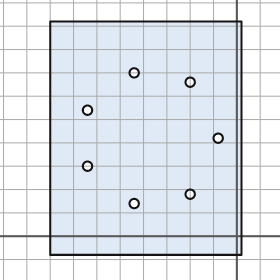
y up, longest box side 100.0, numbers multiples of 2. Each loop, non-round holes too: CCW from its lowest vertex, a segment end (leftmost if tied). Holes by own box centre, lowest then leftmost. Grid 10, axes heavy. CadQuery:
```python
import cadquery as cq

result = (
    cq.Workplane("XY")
    .moveTo(-80.0, -8.0)
    .lineTo(2.0, -8.0)
    .lineTo(2.0, 92.0)
    .lineTo(-80.0, 92.0)
    .close()
    .moveTo(-44.0, 14.0)
    .circle(2.0)
    .moveTo(-20.0, 18.0)
    .circle(2.0)
    .moveTo(-64.0, 30.0)
    .circle(2.0)
    .moveTo(-8.0, 42.0)
    .circle(2.0)
    .moveTo(-64.0, 54.0)
    .circle(2.0)
    .moveTo(-20.0, 66.0)
    .circle(2.0)
    .moveTo(-44.0, 70.0)
    .circle(2.0)
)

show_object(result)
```